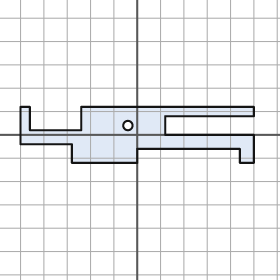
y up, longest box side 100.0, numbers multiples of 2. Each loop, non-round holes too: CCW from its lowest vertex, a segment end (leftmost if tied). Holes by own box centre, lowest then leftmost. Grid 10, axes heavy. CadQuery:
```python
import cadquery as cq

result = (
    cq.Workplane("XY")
    .moveTo(-28.0, -12.0)
    .lineTo(0.0, -12.0)
    .lineTo(0.0, -6.0)
    .lineTo(44.0, -6.0)
    .lineTo(44.0, -12.0)
    .lineTo(50.0, -12.0)
    .lineTo(50.0, 0.0)
    .lineTo(12.0, 0.0)
    .lineTo(12.0, 8.0)
    .lineTo(50.0, 8.0)
    .lineTo(50.0, 12.0)
    .lineTo(-24.0, 12.0)
    .lineTo(-24.0, 2.0)
    .lineTo(-46.0, 2.0)
    .lineTo(-46.0, 12.0)
    .lineTo(-50.0, 12.0)
    .lineTo(-50.0, -4.0)
    .lineTo(-28.0, -4.0)
    .close()
    .moveTo(-4.0, 4.0)
    .circle(2.0)
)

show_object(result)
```